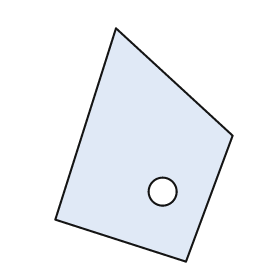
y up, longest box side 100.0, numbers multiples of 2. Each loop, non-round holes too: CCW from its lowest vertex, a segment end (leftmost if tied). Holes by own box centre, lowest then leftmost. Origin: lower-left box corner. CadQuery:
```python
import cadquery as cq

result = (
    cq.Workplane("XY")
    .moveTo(56.0, 0.0)
    .lineTo(76.0, 54.0)
    .lineTo(26.0, 100.0)
    .lineTo(0.0, 18.0)
    .close()
    .moveTo(46.0, 30.0)
    .circle(6.0)
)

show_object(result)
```